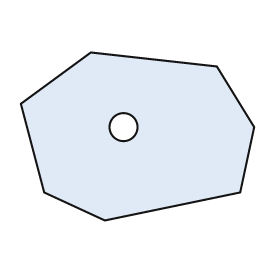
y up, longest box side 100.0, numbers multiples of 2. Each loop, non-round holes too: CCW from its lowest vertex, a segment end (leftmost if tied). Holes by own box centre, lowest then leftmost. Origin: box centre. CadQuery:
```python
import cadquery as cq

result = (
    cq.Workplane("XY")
    .moveTo(-14.0, -36.0)
    .lineTo(44.0, -24.0)
    .lineTo(50.0, 4.0)
    .lineTo(34.0, 30.0)
    .lineTo(-20.0, 36.0)
    .lineTo(-50.0, 14.0)
    .lineTo(-40.0, -24.0)
    .close()
    .moveTo(-6.0, 4.0)
    .circle(6.0)
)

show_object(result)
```